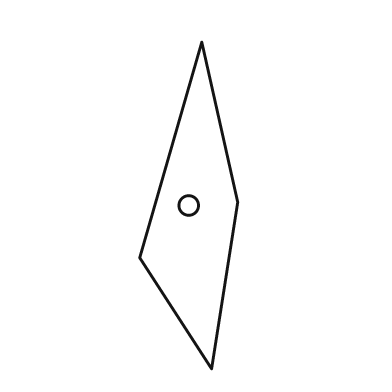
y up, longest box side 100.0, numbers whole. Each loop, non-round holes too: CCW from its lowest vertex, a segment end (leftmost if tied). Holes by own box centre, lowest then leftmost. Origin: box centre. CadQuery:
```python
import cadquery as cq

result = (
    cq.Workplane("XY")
    .moveTo(7.0, -50.0)
    .lineTo(15.0, 1.0)
    .lineTo(4.0, 50.0)
    .lineTo(-15.0, -16.0)
    .close()
    .moveTo(0.0, 0.0)
    .circle(3.0)
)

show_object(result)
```